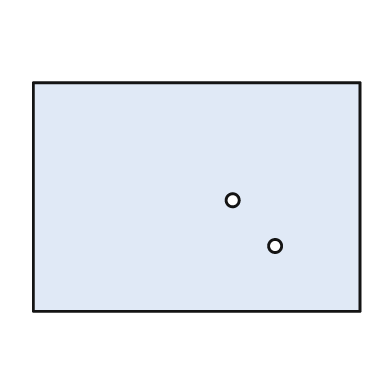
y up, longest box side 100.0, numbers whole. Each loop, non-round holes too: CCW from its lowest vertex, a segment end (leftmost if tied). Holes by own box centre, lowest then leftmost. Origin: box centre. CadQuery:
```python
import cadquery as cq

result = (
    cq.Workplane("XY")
    .moveTo(-50.0, -35.0)
    .lineTo(50.0, -35.0)
    .lineTo(50.0, 35.0)
    .lineTo(-50.0, 35.0)
    .close()
    .moveTo(24.0, -15.0)
    .circle(2.0)
    .moveTo(11.0, -1.0)
    .circle(2.0)
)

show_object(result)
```